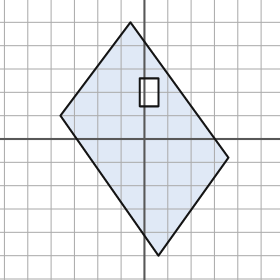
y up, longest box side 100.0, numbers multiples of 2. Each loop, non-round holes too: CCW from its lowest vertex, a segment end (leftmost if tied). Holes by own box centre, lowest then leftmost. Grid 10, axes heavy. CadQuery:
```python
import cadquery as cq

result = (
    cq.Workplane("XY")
    .moveTo(6.0, -50.0)
    .lineTo(36.0, -8.0)
    .lineTo(-6.0, 50.0)
    .lineTo(-36.0, 10.0)
    .close()
    .moveTo(-2.0, 14.0)
    .lineTo(6.0, 14.0)
    .lineTo(6.0, 26.0)
    .lineTo(-2.0, 26.0)
    .close()
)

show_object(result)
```